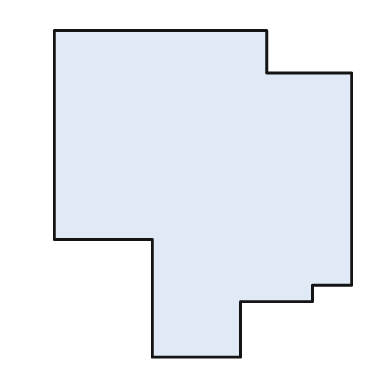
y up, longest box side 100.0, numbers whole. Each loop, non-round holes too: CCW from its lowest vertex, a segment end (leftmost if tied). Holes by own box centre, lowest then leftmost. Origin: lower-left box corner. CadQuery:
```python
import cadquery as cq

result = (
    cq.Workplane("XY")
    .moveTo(30.0, 0.0)
    .lineTo(57.0, 0.0)
    .lineTo(57.0, 17.0)
    .lineTo(79.0, 17.0)
    .lineTo(79.0, 22.0)
    .lineTo(91.0, 22.0)
    .lineTo(91.0, 87.0)
    .lineTo(65.0, 87.0)
    .lineTo(65.0, 100.0)
    .lineTo(0.0, 100.0)
    .lineTo(0.0, 36.0)
    .lineTo(30.0, 36.0)
    .close()
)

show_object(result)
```